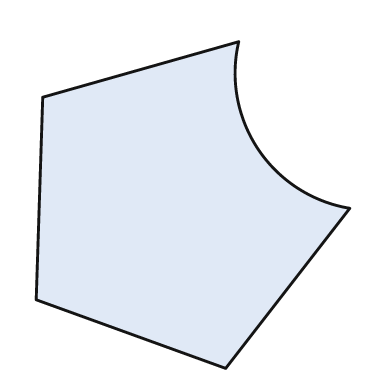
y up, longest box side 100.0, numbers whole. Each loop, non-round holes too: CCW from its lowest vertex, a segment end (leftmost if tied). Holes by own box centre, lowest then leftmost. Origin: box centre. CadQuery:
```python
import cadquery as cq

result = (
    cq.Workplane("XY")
    .moveTo(10.0, -50.0)
    .lineTo(48.0, -1.0)
    .threePointArc((20.0, 17.0), (14.0, 50.0))
    .lineTo(-46.0, 33.0)
    .lineTo(-48.0, -29.0)
    .close()
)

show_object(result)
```